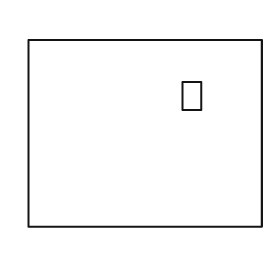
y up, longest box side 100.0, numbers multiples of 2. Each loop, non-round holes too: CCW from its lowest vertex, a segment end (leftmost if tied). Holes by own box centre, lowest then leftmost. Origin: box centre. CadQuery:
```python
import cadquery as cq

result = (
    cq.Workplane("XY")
    .moveTo(-50.0, -40.0)
    .lineTo(50.0, -40.0)
    .lineTo(50.0, 40.0)
    .lineTo(-50.0, 40.0)
    .close()
    .moveTo(16.0, 10.0)
    .lineTo(24.0, 10.0)
    .lineTo(24.0, 22.0)
    .lineTo(16.0, 22.0)
    .close()
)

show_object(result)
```